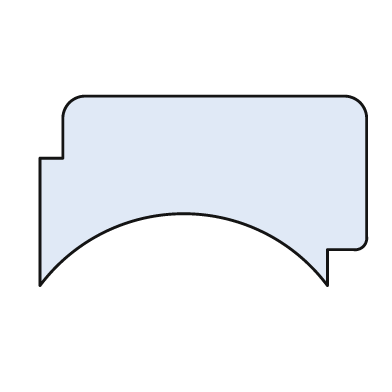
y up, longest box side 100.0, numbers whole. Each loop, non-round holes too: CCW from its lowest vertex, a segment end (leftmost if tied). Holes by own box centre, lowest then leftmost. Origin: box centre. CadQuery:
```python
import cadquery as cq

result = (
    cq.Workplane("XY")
    .moveTo(-50.0, -29.0)
    .threePointArc((-6.0, -7.0), (38.0, -29.0))
    .lineTo(38.0, -18.0)
    .lineTo(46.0, -18.0)
    .threePointArc((49.0, -17.0), (50.0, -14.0))
    .lineTo(50.0, 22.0)
    .threePointArc((48.0, 27.0), (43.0, 29.0))
    .lineTo(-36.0, 29.0)
    .threePointArc((-41.0, 27.0), (-43.0, 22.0))
    .lineTo(-43.0, 10.0)
    .lineTo(-50.0, 10.0)
    .close()
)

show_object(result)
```